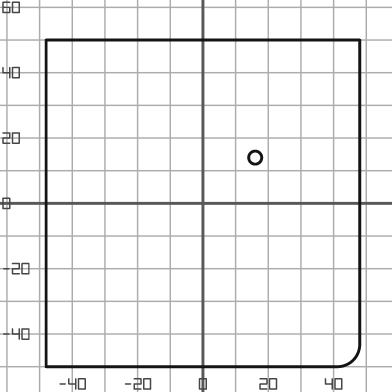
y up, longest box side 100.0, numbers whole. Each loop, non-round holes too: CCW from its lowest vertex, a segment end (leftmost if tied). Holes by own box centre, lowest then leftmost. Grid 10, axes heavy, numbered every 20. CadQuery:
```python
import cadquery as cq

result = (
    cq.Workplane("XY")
    .moveTo(-48.0, -50.0)
    .lineTo(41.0, -50.0)
    .threePointArc((46.0, -48.0), (48.0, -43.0))
    .lineTo(48.0, 50.0)
    .lineTo(-48.0, 50.0)
    .close()
    .moveTo(16.0, 14.0)
    .circle(2.0)
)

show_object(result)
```